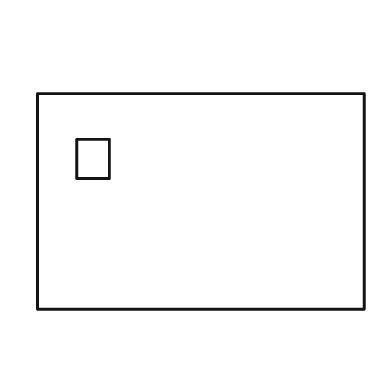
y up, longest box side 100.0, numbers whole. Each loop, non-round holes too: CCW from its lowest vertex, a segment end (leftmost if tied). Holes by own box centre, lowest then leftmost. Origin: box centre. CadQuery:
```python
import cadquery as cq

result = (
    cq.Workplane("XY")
    .moveTo(-50.0, -33.0)
    .lineTo(50.0, -33.0)
    .lineTo(50.0, 33.0)
    .lineTo(-50.0, 33.0)
    .close()
    .moveTo(-38.0, 7.0)
    .lineTo(-28.0, 7.0)
    .lineTo(-28.0, 19.0)
    .lineTo(-38.0, 19.0)
    .close()
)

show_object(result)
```